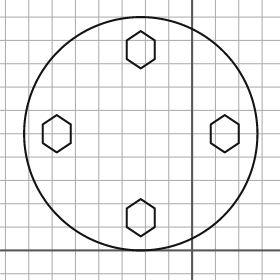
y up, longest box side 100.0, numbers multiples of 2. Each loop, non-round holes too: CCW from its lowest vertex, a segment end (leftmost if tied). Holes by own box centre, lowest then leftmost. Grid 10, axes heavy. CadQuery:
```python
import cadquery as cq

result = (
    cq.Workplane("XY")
    .moveTo(-22.0, 50.0)
    .circle(50.0)
    .moveTo(-22.0, 6.0)
    .lineTo(-16.0, 10.0)
    .lineTo(-16.0, 18.0)
    .lineTo(-22.0, 22.0)
    .lineTo(-28.0, 18.0)
    .lineTo(-28.0, 10.0)
    .close()
    .moveTo(-58.0, 42.0)
    .lineTo(-52.0, 46.0)
    .lineTo(-52.0, 54.0)
    .lineTo(-58.0, 58.0)
    .lineTo(-64.0, 54.0)
    .lineTo(-64.0, 46.0)
    .close()
    .moveTo(14.0, 42.0)
    .lineTo(20.0, 46.0)
    .lineTo(20.0, 54.0)
    .lineTo(14.0, 58.0)
    .lineTo(8.0, 54.0)
    .lineTo(8.0, 46.0)
    .close()
    .moveTo(-22.0, 78.0)
    .lineTo(-16.0, 82.0)
    .lineTo(-16.0, 90.0)
    .lineTo(-22.0, 94.0)
    .lineTo(-28.0, 90.0)
    .lineTo(-28.0, 82.0)
    .close()
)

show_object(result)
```